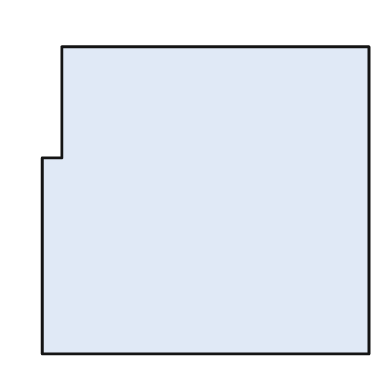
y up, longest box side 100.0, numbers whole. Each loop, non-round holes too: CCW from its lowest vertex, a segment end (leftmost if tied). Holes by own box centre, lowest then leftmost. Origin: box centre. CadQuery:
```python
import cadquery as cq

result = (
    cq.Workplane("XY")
    .moveTo(-50.0, -47.0)
    .lineTo(50.0, -47.0)
    .lineTo(50.0, 47.0)
    .lineTo(-44.0, 47.0)
    .lineTo(-44.0, 13.0)
    .lineTo(-50.0, 13.0)
    .close()
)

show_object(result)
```